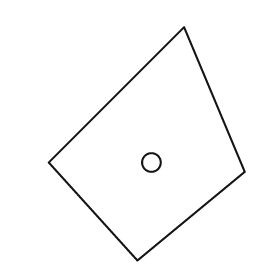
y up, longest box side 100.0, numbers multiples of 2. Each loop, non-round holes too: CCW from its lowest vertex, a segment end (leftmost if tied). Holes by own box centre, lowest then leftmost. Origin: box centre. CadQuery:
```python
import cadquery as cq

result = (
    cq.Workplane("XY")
    .moveTo(-4.0, -50.0)
    .lineTo(42.0, -12.0)
    .lineTo(16.0, 50.0)
    .lineTo(-42.0, -8.0)
    .close()
    .moveTo(2.0, -8.0)
    .circle(4.0)
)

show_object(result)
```